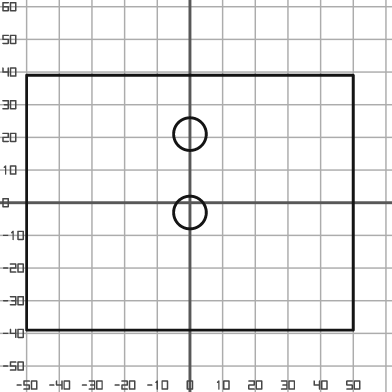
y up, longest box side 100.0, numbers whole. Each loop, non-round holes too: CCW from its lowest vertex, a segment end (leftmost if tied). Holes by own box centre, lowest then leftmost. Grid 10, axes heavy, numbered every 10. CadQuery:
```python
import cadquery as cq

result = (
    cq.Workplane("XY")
    .moveTo(-50.0, -39.0)
    .lineTo(50.0, -39.0)
    .lineTo(50.0, 39.0)
    .lineTo(-50.0, 39.0)
    .close()
    .moveTo(0.0, -3.0)
    .circle(5.0)
    .moveTo(0.0, 21.0)
    .circle(5.0)
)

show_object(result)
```